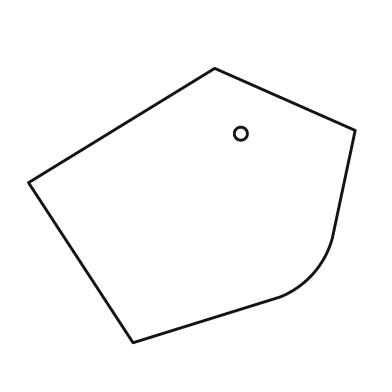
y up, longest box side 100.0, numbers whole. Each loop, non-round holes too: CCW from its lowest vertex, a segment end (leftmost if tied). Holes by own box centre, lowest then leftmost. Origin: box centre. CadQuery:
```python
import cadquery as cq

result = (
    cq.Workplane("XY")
    .moveTo(-18.0, -42.0)
    .lineTo(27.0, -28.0)
    .threePointArc((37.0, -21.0), (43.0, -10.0))
    .lineTo(50.0, 23.0)
    .lineTo(7.0, 42.0)
    .lineTo(-50.0, 7.0)
    .close()
    .moveTo(15.0, 22.0)
    .circle(2.0)
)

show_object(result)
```